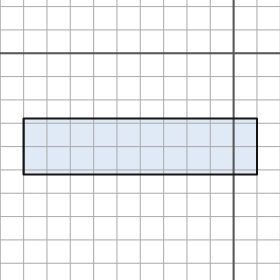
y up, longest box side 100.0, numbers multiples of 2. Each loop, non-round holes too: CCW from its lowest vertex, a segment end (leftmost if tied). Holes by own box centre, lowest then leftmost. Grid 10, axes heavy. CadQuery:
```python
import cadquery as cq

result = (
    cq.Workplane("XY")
    .moveTo(-90.0, -52.0)
    .lineTo(10.0, -52.0)
    .lineTo(10.0, -28.0)
    .lineTo(-90.0, -28.0)
    .close()
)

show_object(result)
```